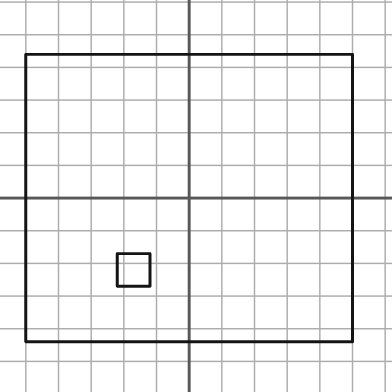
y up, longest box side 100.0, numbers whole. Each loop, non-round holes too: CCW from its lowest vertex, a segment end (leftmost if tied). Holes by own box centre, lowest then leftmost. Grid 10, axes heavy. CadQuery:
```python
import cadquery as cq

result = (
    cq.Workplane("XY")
    .moveTo(-50.0, -44.0)
    .lineTo(50.0, -44.0)
    .lineTo(50.0, 44.0)
    .lineTo(-50.0, 44.0)
    .close()
    .moveTo(-22.0, -27.0)
    .lineTo(-12.0, -27.0)
    .lineTo(-12.0, -17.0)
    .lineTo(-22.0, -17.0)
    .close()
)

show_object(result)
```